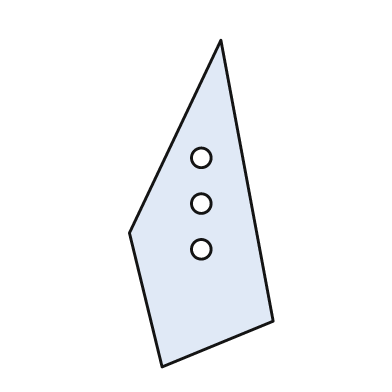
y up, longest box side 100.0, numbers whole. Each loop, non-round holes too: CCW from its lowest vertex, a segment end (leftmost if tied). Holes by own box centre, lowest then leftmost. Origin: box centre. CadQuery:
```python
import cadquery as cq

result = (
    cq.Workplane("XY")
    .moveTo(-12.0, -50.0)
    .lineTo(22.0, -36.0)
    .lineTo(6.0, 50.0)
    .lineTo(-22.0, -9.0)
    .close()
    .moveTo(0.0, -14.0)
    .circle(3.0)
    .moveTo(0.0, 0.0)
    .circle(3.0)
    .moveTo(0.0, 14.0)
    .circle(3.0)
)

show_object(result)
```